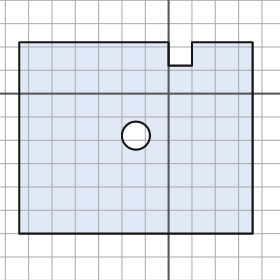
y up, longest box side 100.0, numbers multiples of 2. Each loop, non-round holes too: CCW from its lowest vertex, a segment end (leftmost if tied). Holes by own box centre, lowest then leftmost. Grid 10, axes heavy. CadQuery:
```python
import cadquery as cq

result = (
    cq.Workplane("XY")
    .moveTo(-64.0, -60.0)
    .lineTo(36.0, -60.0)
    .lineTo(36.0, 22.0)
    .lineTo(10.0, 22.0)
    .lineTo(10.0, 12.0)
    .lineTo(0.0, 12.0)
    .lineTo(0.0, 22.0)
    .lineTo(-64.0, 22.0)
    .close()
    .moveTo(-14.0, -18.0)
    .circle(6.0)
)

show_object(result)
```